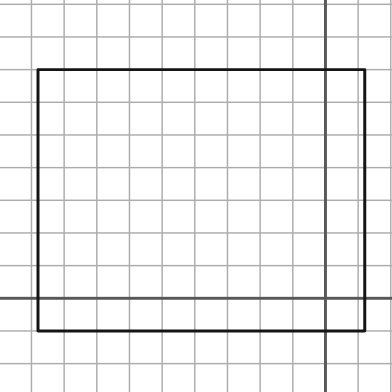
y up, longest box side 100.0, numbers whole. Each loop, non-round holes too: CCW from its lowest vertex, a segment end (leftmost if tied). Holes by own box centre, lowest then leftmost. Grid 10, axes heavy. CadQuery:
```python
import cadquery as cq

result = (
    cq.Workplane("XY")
    .moveTo(-88.0, -10.0)
    .lineTo(12.0, -10.0)
    .lineTo(12.0, 70.0)
    .lineTo(-88.0, 70.0)
    .close()
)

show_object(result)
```